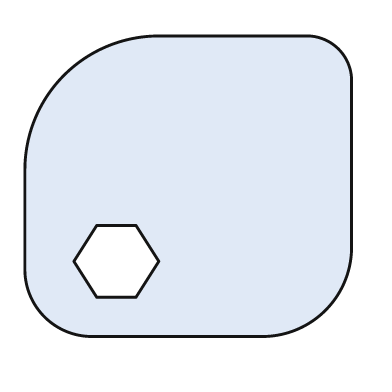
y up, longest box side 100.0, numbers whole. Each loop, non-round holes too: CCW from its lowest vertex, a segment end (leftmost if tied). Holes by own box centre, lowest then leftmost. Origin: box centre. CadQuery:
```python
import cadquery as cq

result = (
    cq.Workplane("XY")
    .moveTo(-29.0, -46.0)
    .lineTo(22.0, -46.0)
    .threePointArc((42.0, -38.0), (50.0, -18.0))
    .lineTo(50.0, 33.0)
    .threePointArc((46.0, 42.0), (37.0, 46.0))
    .lineTo(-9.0, 46.0)
    .threePointArc((-38.0, 34.0), (-50.0, 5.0))
    .lineTo(-50.0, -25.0)
    .threePointArc((-44.0, -40.0), (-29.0, -46.0))
    .close()
    .moveTo(-28.0, -34.0)
    .lineTo(-16.0, -34.0)
    .lineTo(-9.0, -23.0)
    .lineTo(-16.0, -12.0)
    .lineTo(-28.0, -12.0)
    .lineTo(-35.0, -23.0)
    .close()
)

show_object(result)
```